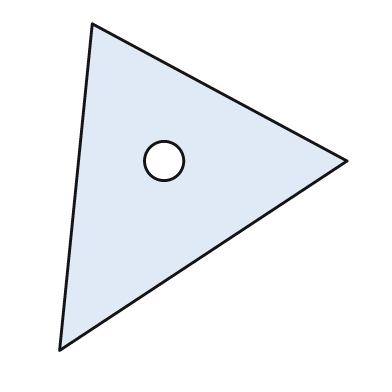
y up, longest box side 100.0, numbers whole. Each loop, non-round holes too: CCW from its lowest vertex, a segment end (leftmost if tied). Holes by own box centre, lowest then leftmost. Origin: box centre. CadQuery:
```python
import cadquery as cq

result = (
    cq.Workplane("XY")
    .moveTo(-44.0, -50.0)
    .lineTo(44.0, 8.0)
    .lineTo(-34.0, 50.0)
    .close()
    .moveTo(-12.0, 8.0)
    .circle(6.0)
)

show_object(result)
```